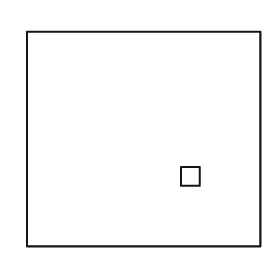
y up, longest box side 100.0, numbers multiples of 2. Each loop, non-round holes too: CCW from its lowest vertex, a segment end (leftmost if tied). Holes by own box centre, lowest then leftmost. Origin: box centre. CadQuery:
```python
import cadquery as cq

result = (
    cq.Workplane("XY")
    .moveTo(-50.0, -46.0)
    .lineTo(50.0, -46.0)
    .lineTo(50.0, 46.0)
    .lineTo(-50.0, 46.0)
    .close()
    .moveTo(16.0, -20.0)
    .lineTo(24.0, -20.0)
    .lineTo(24.0, -12.0)
    .lineTo(16.0, -12.0)
    .close()
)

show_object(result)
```